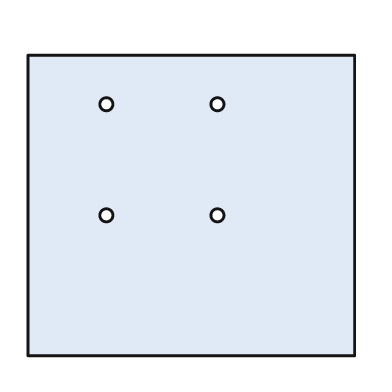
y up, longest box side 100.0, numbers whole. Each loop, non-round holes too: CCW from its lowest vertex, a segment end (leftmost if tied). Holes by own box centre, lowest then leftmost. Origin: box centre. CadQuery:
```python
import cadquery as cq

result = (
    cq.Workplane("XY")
    .moveTo(-50.0, -46.0)
    .lineTo(50.0, -46.0)
    .lineTo(50.0, 46.0)
    .lineTo(-50.0, 46.0)
    .close()
    .moveTo(-26.0, -3.0)
    .circle(2.0)
    .moveTo(8.0, -3.0)
    .circle(2.0)
    .moveTo(-26.0, 31.0)
    .circle(2.0)
    .moveTo(8.0, 31.0)
    .circle(2.0)
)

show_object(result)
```